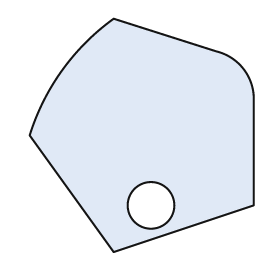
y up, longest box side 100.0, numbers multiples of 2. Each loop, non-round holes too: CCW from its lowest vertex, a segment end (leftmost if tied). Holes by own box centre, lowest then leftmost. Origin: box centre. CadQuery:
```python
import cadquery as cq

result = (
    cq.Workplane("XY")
    .moveTo(-12.0, -50.0)
    .lineTo(48.0, -30.0)
    .lineTo(48.0, 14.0)
    .threePointArc((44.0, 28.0), (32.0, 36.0))
    .lineTo(-12.0, 50.0)
    .threePointArc((-34.0, 28.0), (-48.0, 0.0))
    .close()
    .moveTo(4.0, -30.0)
    .circle(10.0)
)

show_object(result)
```